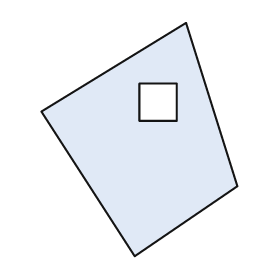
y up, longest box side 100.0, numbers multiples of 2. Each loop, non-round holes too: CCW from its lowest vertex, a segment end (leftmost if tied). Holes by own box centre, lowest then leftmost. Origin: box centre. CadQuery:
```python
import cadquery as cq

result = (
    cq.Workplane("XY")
    .moveTo(-2.0, -50.0)
    .lineTo(42.0, -20.0)
    .lineTo(20.0, 50.0)
    .lineTo(-42.0, 12.0)
    .close()
    .moveTo(0.0, 8.0)
    .lineTo(16.0, 8.0)
    .lineTo(16.0, 24.0)
    .lineTo(0.0, 24.0)
    .close()
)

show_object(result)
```